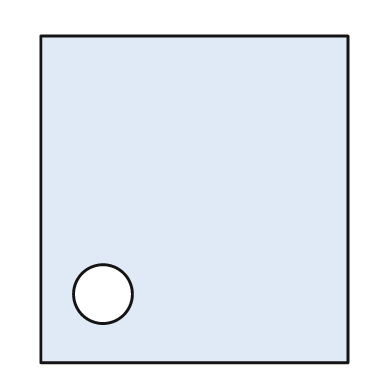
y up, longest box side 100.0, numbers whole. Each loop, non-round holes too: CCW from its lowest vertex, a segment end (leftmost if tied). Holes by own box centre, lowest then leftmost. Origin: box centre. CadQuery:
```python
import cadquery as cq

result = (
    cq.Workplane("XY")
    .moveTo(-47.0, -50.0)
    .lineTo(47.0, -50.0)
    .lineTo(47.0, 50.0)
    .lineTo(-47.0, 50.0)
    .close()
    .moveTo(-28.0, -29.0)
    .circle(9.0)
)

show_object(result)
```